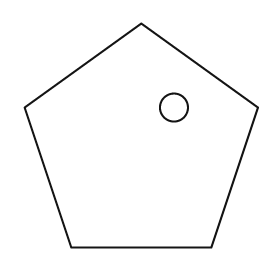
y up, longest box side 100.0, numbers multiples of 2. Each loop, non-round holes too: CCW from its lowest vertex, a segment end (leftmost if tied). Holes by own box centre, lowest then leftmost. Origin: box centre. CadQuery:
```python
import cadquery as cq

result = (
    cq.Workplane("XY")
    .moveTo(-30.0, -48.0)
    .lineTo(30.0, -48.0)
    .lineTo(50.0, 12.0)
    .lineTo(0.0, 48.0)
    .lineTo(-50.0, 12.0)
    .close()
    .moveTo(14.0, 12.0)
    .circle(6.0)
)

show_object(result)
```